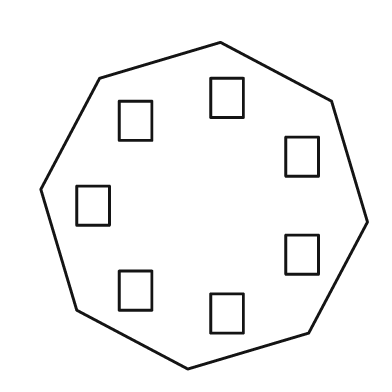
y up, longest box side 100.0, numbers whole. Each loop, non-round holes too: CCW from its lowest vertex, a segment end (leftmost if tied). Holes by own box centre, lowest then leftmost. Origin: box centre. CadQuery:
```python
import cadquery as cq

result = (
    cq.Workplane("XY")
    .moveTo(-5.0, -50.0)
    .lineTo(32.0, -39.0)
    .lineTo(50.0, -5.0)
    .lineTo(39.0, 32.0)
    .lineTo(5.0, 50.0)
    .lineTo(-32.0, 39.0)
    .lineTo(-50.0, 5.0)
    .lineTo(-39.0, -32.0)
    .close()
    .moveTo(2.0, -39.0)
    .lineTo(12.0, -39.0)
    .lineTo(12.0, -27.0)
    .lineTo(2.0, -27.0)
    .close()
    .moveTo(-26.0, -32.0)
    .lineTo(-16.0, -32.0)
    .lineTo(-16.0, -20.0)
    .lineTo(-26.0, -20.0)
    .close()
    .moveTo(25.0, -21.0)
    .lineTo(35.0, -21.0)
    .lineTo(35.0, -9.0)
    .lineTo(25.0, -9.0)
    .close()
    .moveTo(-39.0, -6.0)
    .lineTo(-29.0, -6.0)
    .lineTo(-29.0, 6.0)
    .lineTo(-39.0, 6.0)
    .close()
    .moveTo(25.0, 9.0)
    .lineTo(35.0, 9.0)
    .lineTo(35.0, 21.0)
    .lineTo(25.0, 21.0)
    .close()
    .moveTo(-26.0, 20.0)
    .lineTo(-16.0, 20.0)
    .lineTo(-16.0, 32.0)
    .lineTo(-26.0, 32.0)
    .close()
    .moveTo(2.0, 27.0)
    .lineTo(12.0, 27.0)
    .lineTo(12.0, 39.0)
    .lineTo(2.0, 39.0)
    .close()
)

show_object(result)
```